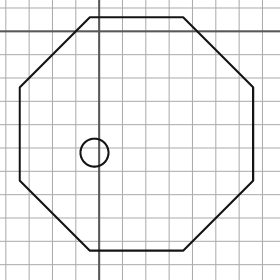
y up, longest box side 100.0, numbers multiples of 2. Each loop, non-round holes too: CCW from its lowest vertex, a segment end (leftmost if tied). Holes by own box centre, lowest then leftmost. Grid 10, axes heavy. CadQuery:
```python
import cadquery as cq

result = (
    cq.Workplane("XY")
    .moveTo(-4.0, -94.0)
    .lineTo(36.0, -94.0)
    .lineTo(66.0, -64.0)
    .lineTo(66.0, -24.0)
    .lineTo(36.0, 6.0)
    .lineTo(-4.0, 6.0)
    .lineTo(-34.0, -24.0)
    .lineTo(-34.0, -64.0)
    .close()
    .moveTo(-2.0, -52.0)
    .circle(6.0)
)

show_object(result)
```